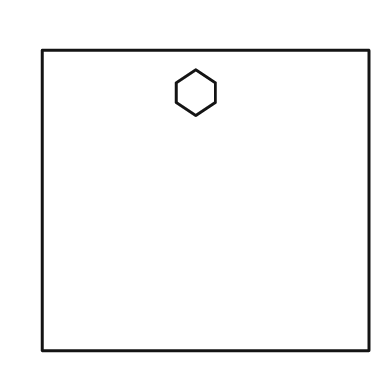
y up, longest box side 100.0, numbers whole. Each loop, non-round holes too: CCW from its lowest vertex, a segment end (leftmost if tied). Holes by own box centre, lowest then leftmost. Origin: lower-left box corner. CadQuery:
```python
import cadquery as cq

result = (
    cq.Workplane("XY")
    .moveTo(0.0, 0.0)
    .lineTo(100.0, 0.0)
    .lineTo(100.0, 92.0)
    .lineTo(0.0, 92.0)
    .close()
    .moveTo(47.0, 72.0)
    .lineTo(53.0, 76.0)
    .lineTo(53.0, 82.0)
    .lineTo(47.0, 86.0)
    .lineTo(41.0, 82.0)
    .lineTo(41.0, 76.0)
    .close()
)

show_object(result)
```